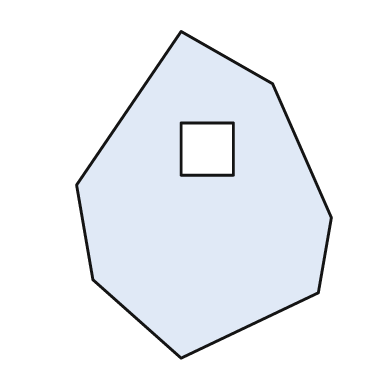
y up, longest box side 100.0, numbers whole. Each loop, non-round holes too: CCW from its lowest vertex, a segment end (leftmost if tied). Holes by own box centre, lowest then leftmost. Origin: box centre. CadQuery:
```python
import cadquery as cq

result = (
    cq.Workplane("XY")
    .moveTo(-7.0, -50.0)
    .lineTo(35.0, -30.0)
    .lineTo(39.0, -7.0)
    .lineTo(21.0, 34.0)
    .lineTo(-7.0, 50.0)
    .lineTo(-39.0, 3.0)
    .lineTo(-34.0, -26.0)
    .close()
    .moveTo(-7.0, 6.0)
    .lineTo(9.0, 6.0)
    .lineTo(9.0, 22.0)
    .lineTo(-7.0, 22.0)
    .close()
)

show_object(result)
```